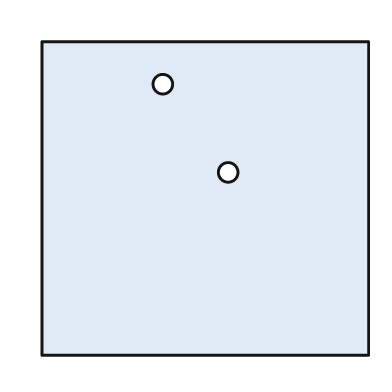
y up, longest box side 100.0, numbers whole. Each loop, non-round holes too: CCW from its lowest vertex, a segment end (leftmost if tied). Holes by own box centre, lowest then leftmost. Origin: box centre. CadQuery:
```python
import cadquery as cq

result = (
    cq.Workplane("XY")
    .moveTo(-50.0, -48.0)
    .lineTo(50.0, -48.0)
    .lineTo(50.0, 48.0)
    .lineTo(-50.0, 48.0)
    .close()
    .moveTo(7.0, 8.0)
    .circle(3.0)
    .moveTo(-13.0, 35.0)
    .circle(3.0)
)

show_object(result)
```